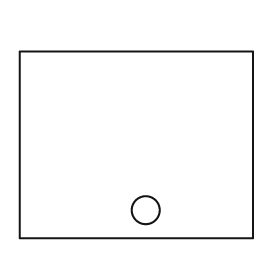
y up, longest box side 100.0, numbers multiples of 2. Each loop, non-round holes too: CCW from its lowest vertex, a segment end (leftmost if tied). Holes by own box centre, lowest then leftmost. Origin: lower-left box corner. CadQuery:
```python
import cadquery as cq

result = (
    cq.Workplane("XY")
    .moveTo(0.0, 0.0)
    .lineTo(100.0, 0.0)
    .lineTo(100.0, 80.0)
    .lineTo(0.0, 80.0)
    .close()
    .moveTo(54.0, 12.0)
    .circle(6.0)
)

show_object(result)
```